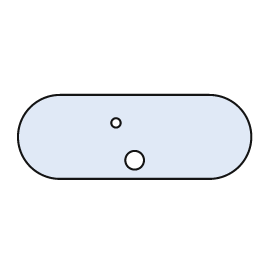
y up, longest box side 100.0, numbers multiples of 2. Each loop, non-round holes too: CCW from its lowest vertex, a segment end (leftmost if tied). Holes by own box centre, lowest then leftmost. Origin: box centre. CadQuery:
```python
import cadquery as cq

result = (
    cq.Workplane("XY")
    .moveTo(-32.0, -18.0)
    .lineTo(32.0, -18.0)
    .threePointArc((50.0, 0.0), (32.0, 18.0))
    .lineTo(-32.0, 18.0)
    .threePointArc((-50.0, 0.0), (-32.0, -18.0))
    .close()
    .moveTo(0.0, -10.0)
    .circle(4.0)
    .moveTo(-8.0, 6.0)
    .circle(2.0)
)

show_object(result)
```